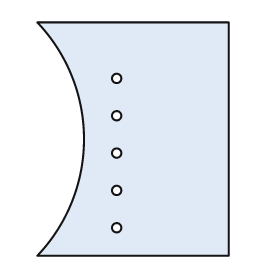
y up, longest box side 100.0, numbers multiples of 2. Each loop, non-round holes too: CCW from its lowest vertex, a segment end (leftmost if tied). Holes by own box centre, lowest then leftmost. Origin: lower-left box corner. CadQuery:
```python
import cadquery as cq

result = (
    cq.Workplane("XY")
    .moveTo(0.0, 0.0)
    .lineTo(82.0, 0.0)
    .lineTo(82.0, 100.0)
    .lineTo(0.0, 100.0)
    .threePointArc((20.0, 50.0), (0.0, 0.0))
    .close()
    .moveTo(34.0, 12.0)
    .circle(2.0)
    .moveTo(34.0, 28.0)
    .circle(2.0)
    .moveTo(34.0, 44.0)
    .circle(2.0)
    .moveTo(34.0, 60.0)
    .circle(2.0)
    .moveTo(34.0, 76.0)
    .circle(2.0)
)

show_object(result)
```